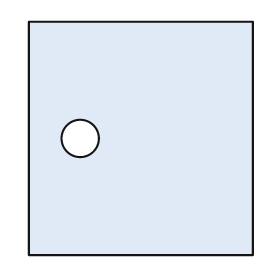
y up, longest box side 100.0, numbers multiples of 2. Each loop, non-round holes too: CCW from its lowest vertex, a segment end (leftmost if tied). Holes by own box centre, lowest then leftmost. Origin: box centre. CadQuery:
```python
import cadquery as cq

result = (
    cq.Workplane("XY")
    .moveTo(-48.0, -50.0)
    .lineTo(48.0, -50.0)
    .lineTo(48.0, 50.0)
    .lineTo(-48.0, 50.0)
    .close()
    .moveTo(-26.0, 0.0)
    .circle(8.0)
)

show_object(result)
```